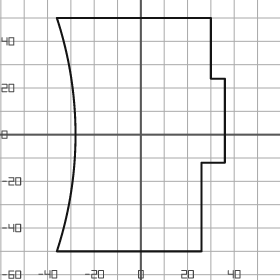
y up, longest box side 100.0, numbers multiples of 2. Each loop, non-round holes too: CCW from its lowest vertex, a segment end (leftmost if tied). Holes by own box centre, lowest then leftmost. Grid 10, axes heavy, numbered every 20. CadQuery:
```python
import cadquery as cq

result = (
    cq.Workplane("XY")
    .moveTo(-36.0, -50.0)
    .lineTo(26.0, -50.0)
    .lineTo(26.0, -12.0)
    .lineTo(36.0, -12.0)
    .lineTo(36.0, 24.0)
    .lineTo(30.0, 24.0)
    .lineTo(30.0, 50.0)
    .lineTo(-36.0, 50.0)
    .threePointArc((-28.0, 0.0), (-36.0, -50.0))
    .close()
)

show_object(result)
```